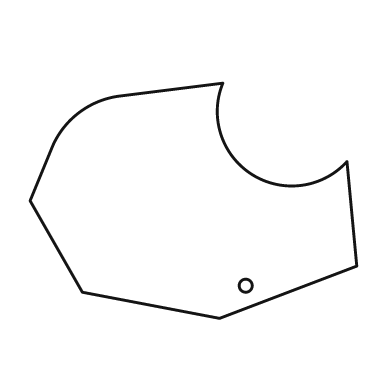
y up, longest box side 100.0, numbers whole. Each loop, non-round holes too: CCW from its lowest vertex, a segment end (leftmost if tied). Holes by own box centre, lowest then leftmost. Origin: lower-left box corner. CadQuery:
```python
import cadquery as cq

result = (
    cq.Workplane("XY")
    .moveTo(58.0, 0.0)
    .lineTo(100.0, 16.0)
    .lineTo(97.0, 48.0)
    .threePointArc((68.0, 44.0), (59.0, 72.0))
    .lineTo(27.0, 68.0)
    .threePointArc((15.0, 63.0), (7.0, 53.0))
    .lineTo(0.0, 36.0)
    .lineTo(16.0, 8.0)
    .close()
    .moveTo(66.0, 10.0)
    .circle(2.0)
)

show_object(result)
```